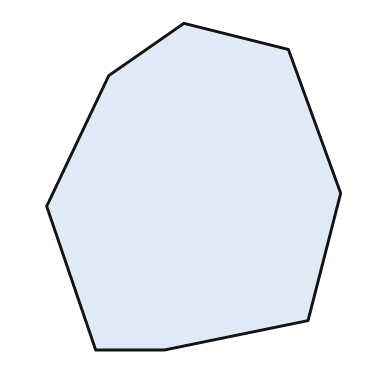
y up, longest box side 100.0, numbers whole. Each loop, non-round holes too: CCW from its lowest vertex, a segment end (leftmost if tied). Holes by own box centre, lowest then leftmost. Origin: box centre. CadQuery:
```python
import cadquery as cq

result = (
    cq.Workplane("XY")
    .moveTo(-30.0, -50.0)
    .lineTo(-9.0, -50.0)
    .lineTo(35.0, -41.0)
    .lineTo(45.0, -2.0)
    .lineTo(29.0, 42.0)
    .lineTo(-3.0, 50.0)
    .lineTo(-26.0, 34.0)
    .lineTo(-45.0, -6.0)
    .close()
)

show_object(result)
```